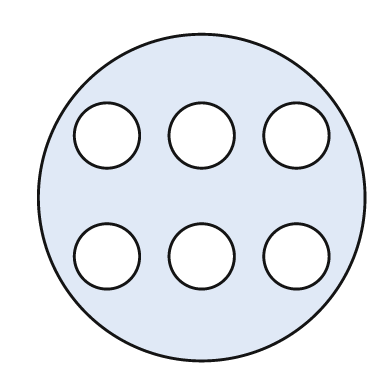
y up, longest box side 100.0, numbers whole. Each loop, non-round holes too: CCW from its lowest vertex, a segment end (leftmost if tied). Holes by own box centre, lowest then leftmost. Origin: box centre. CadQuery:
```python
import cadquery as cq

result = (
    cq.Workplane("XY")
    .moveTo(0.0, 0.0)
    .circle(50.0)
    .moveTo(-29.0, -18.0)
    .circle(10.0)
    .moveTo(0.0, -18.0)
    .circle(10.0)
    .moveTo(29.0, -18.0)
    .circle(10.0)
    .moveTo(-29.0, 19.0)
    .circle(10.0)
    .moveTo(0.0, 19.0)
    .circle(10.0)
    .moveTo(29.0, 19.0)
    .circle(10.0)
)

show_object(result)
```